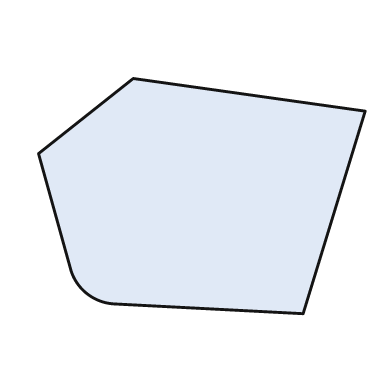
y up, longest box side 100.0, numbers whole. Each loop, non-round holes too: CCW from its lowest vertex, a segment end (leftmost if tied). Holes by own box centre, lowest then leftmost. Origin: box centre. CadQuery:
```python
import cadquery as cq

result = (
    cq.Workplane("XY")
    .moveTo(31.0, -36.0)
    .lineTo(50.0, 26.0)
    .lineTo(-21.0, 36.0)
    .lineTo(-50.0, 13.0)
    .lineTo(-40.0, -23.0)
    .threePointArc((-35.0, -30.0), (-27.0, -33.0))
    .close()
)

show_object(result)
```